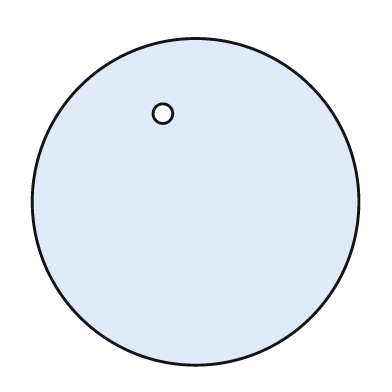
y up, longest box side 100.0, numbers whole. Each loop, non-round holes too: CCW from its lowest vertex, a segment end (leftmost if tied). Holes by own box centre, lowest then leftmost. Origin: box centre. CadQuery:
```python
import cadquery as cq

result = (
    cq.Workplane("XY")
    .moveTo(0.0, 0.0)
    .circle(50.0)
    .moveTo(-10.0, 27.0)
    .circle(3.0)
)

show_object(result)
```